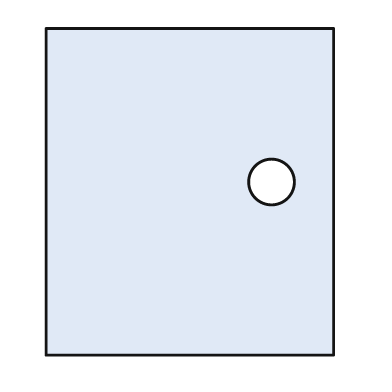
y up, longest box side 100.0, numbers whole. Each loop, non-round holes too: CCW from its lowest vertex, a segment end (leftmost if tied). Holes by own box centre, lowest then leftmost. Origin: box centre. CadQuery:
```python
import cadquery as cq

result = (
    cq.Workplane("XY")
    .moveTo(-44.0, -50.0)
    .lineTo(44.0, -50.0)
    .lineTo(44.0, 50.0)
    .lineTo(-44.0, 50.0)
    .close()
    .moveTo(25.0, 3.0)
    .circle(7.0)
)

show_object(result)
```